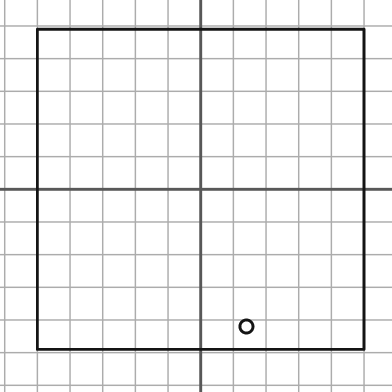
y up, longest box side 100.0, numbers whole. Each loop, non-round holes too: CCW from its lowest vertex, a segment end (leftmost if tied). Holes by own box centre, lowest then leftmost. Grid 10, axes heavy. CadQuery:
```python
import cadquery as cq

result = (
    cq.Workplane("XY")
    .moveTo(-50.0, -49.0)
    .lineTo(50.0, -49.0)
    .lineTo(50.0, 49.0)
    .lineTo(-50.0, 49.0)
    .close()
    .moveTo(14.0, -42.0)
    .circle(2.0)
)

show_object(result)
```